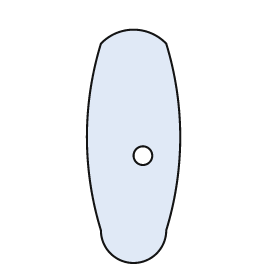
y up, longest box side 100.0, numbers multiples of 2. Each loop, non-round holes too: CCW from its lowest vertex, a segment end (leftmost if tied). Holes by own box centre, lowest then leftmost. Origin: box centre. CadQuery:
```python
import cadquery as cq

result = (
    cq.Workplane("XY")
    .moveTo(-14.0, -36.0)
    .threePointArc((0.0, -50.0), (14.0, -36.0))
    .threePointArc((20.0, 4.0), (14.0, 44.0))
    .threePointArc((0.0, 50.0), (-14.0, 44.0))
    .threePointArc((-20.0, 4.0), (-14.0, -36.0))
    .close()
    .moveTo(4.0, -4.0)
    .circle(4.0)
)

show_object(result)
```